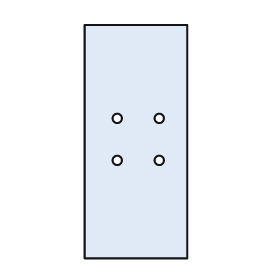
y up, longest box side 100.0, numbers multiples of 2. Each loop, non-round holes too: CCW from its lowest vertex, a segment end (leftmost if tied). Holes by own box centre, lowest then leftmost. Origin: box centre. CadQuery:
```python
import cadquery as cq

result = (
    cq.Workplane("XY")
    .moveTo(-22.0, -50.0)
    .lineTo(22.0, -50.0)
    .lineTo(22.0, 50.0)
    .lineTo(-22.0, 50.0)
    .close()
    .moveTo(-8.0, -8.0)
    .circle(2.0)
    .moveTo(10.0, -8.0)
    .circle(2.0)
    .moveTo(-8.0, 10.0)
    .circle(2.0)
    .moveTo(10.0, 10.0)
    .circle(2.0)
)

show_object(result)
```